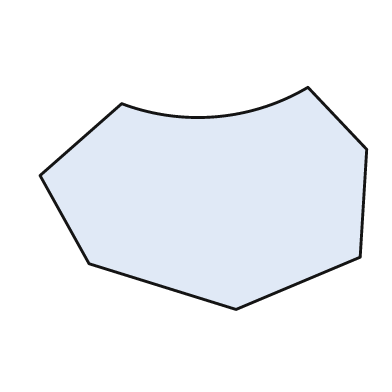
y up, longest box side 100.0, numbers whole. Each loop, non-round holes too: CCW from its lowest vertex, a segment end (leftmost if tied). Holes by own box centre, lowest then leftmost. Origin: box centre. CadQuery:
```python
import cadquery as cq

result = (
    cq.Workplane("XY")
    .moveTo(10.0, -34.0)
    .lineTo(48.0, -18.0)
    .lineTo(50.0, 15.0)
    .lineTo(32.0, 34.0)
    .threePointArc((4.0, 25.0), (-25.0, 29.0))
    .lineTo(-50.0, 7.0)
    .lineTo(-35.0, -20.0)
    .close()
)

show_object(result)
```